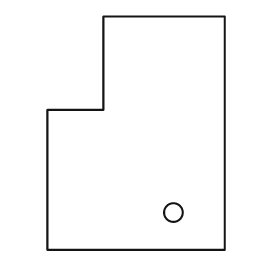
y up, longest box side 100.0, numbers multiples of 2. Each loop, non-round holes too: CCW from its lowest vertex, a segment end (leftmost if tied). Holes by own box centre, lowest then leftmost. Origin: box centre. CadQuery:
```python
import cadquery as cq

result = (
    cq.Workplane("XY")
    .moveTo(-38.0, -50.0)
    .lineTo(38.0, -50.0)
    .lineTo(38.0, 50.0)
    .lineTo(-14.0, 50.0)
    .lineTo(-14.0, 10.0)
    .lineTo(-38.0, 10.0)
    .close()
    .moveTo(16.0, -34.0)
    .circle(4.0)
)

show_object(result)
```